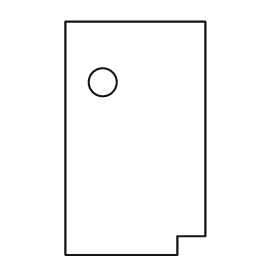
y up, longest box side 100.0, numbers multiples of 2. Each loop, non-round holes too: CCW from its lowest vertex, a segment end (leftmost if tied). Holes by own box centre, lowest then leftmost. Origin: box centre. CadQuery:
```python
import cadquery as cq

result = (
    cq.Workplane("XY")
    .moveTo(-30.0, -50.0)
    .lineTo(18.0, -50.0)
    .lineTo(18.0, -42.0)
    .lineTo(30.0, -42.0)
    .lineTo(30.0, 50.0)
    .lineTo(-30.0, 50.0)
    .close()
    .moveTo(-14.0, 24.0)
    .circle(6.0)
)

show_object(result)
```